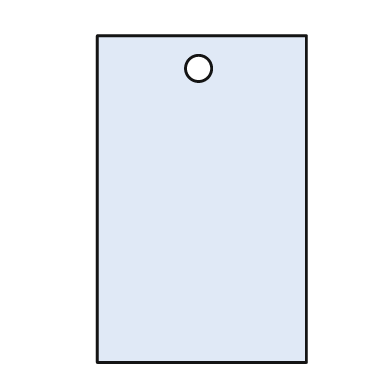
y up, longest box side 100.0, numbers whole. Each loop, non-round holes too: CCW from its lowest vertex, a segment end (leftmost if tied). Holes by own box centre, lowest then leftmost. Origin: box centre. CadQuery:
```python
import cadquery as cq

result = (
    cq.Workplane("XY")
    .moveTo(-32.0, -50.0)
    .lineTo(32.0, -50.0)
    .lineTo(32.0, 50.0)
    .lineTo(-32.0, 50.0)
    .close()
    .moveTo(-1.0, 40.0)
    .circle(4.0)
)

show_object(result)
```